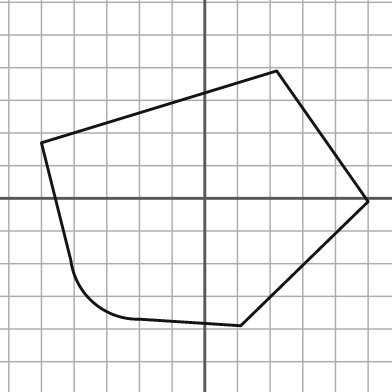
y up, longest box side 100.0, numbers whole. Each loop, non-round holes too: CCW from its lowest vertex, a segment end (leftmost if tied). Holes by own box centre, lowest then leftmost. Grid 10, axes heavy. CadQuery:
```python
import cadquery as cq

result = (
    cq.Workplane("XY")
    .moveTo(11.0, -39.0)
    .lineTo(50.0, -1.0)
    .lineTo(22.0, 39.0)
    .lineTo(-50.0, 17.0)
    .lineTo(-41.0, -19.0)
    .threePointArc((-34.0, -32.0), (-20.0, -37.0))
    .close()
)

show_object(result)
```